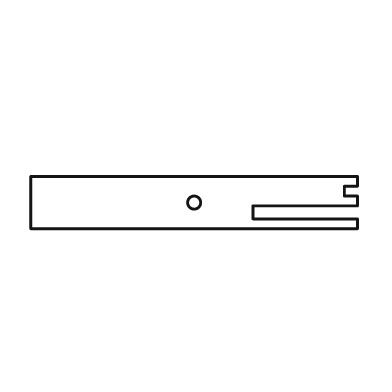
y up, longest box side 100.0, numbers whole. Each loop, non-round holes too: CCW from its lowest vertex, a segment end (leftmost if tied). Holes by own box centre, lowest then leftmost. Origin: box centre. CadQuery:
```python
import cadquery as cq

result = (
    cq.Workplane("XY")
    .moveTo(-50.0, -8.0)
    .lineTo(50.0, -8.0)
    .lineTo(50.0, -5.0)
    .lineTo(18.0, -5.0)
    .lineTo(18.0, -1.0)
    .lineTo(50.0, -1.0)
    .lineTo(50.0, 2.0)
    .lineTo(46.0, 2.0)
    .lineTo(46.0, 5.0)
    .lineTo(50.0, 5.0)
    .lineTo(50.0, 8.0)
    .lineTo(-50.0, 8.0)
    .close()
    .moveTo(0.0, 0.0)
    .circle(2.0)
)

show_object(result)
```